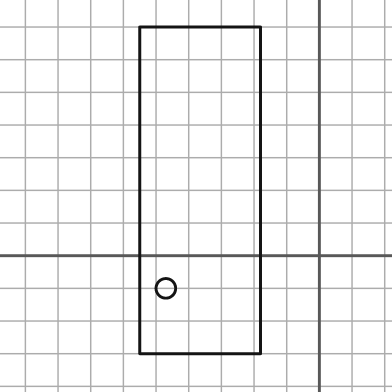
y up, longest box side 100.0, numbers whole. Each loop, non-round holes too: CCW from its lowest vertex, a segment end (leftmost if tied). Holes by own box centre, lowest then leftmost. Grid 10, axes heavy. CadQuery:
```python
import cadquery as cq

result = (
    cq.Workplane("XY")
    .moveTo(-55.0, -30.0)
    .lineTo(-18.0, -30.0)
    .lineTo(-18.0, 70.0)
    .lineTo(-55.0, 70.0)
    .close()
    .moveTo(-47.0, -10.0)
    .circle(3.0)
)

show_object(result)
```